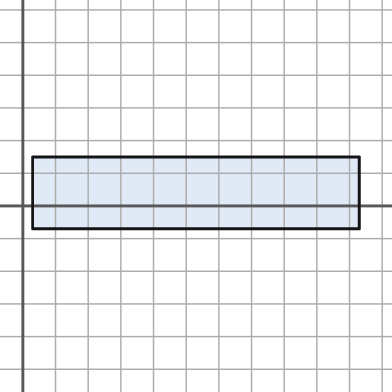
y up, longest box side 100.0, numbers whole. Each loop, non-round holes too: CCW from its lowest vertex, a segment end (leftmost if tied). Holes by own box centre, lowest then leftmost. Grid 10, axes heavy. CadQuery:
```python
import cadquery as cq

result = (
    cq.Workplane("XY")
    .moveTo(3.0, -7.0)
    .lineTo(103.0, -7.0)
    .lineTo(103.0, 15.0)
    .lineTo(3.0, 15.0)
    .close()
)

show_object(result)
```